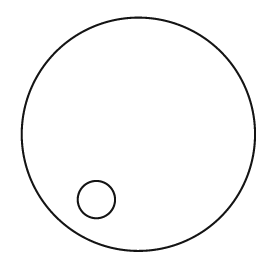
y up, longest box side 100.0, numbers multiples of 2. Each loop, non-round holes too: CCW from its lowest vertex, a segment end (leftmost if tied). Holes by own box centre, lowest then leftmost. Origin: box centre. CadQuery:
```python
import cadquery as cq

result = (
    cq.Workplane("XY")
    .moveTo(0.0, 0.0)
    .circle(50.0)
    .moveTo(-18.0, -28.0)
    .circle(8.0)
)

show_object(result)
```